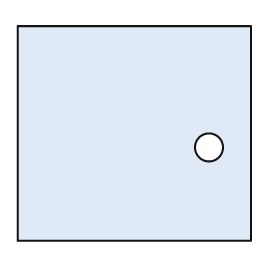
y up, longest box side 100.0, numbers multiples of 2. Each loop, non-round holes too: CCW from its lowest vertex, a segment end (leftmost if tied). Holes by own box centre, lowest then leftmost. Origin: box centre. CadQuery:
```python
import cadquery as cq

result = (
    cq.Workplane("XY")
    .moveTo(-50.0, -46.0)
    .lineTo(50.0, -46.0)
    .lineTo(50.0, 46.0)
    .lineTo(-50.0, 46.0)
    .close()
    .moveTo(32.0, -6.0)
    .circle(6.0)
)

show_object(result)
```